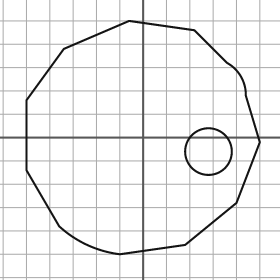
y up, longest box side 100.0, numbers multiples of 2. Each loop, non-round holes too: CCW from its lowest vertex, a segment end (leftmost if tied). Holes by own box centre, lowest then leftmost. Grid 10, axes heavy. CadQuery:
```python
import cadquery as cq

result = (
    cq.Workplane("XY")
    .moveTo(-10.0, -50.0)
    .lineTo(18.0, -46.0)
    .lineTo(40.0, -28.0)
    .lineTo(50.0, -2.0)
    .lineTo(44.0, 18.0)
    .threePointArc((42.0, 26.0), (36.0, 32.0))
    .lineTo(22.0, 46.0)
    .lineTo(-6.0, 50.0)
    .lineTo(-34.0, 38.0)
    .lineTo(-50.0, 16.0)
    .lineTo(-50.0, -14.0)
    .lineTo(-36.0, -38.0)
    .threePointArc((-24.0, -46.0), (-10.0, -50.0))
    .close()
    .moveTo(28.0, -6.0)
    .circle(10.0)
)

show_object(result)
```